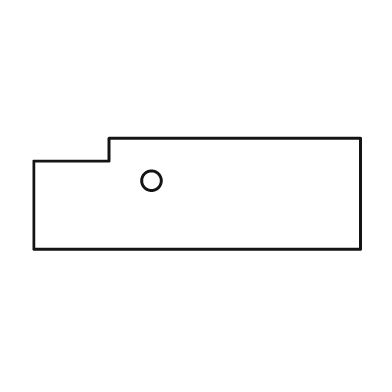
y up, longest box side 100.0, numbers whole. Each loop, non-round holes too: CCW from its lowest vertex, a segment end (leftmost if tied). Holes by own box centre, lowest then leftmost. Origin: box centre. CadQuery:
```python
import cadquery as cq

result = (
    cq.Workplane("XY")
    .moveTo(-50.0, -17.0)
    .lineTo(50.0, -17.0)
    .lineTo(50.0, 17.0)
    .lineTo(-27.0, 17.0)
    .lineTo(-27.0, 10.0)
    .lineTo(-50.0, 10.0)
    .close()
    .moveTo(-14.0, 4.0)
    .circle(3.0)
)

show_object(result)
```